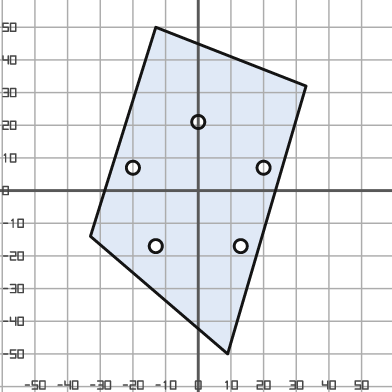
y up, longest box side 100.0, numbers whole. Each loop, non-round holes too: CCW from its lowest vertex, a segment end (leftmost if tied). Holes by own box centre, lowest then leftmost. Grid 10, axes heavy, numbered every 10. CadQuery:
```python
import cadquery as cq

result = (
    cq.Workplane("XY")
    .moveTo(9.0, -50.0)
    .lineTo(33.0, 32.0)
    .lineTo(-13.0, 50.0)
    .lineTo(-33.0, -14.0)
    .close()
    .moveTo(-13.0, -17.0)
    .circle(2.0)
    .moveTo(13.0, -17.0)
    .circle(2.0)
    .moveTo(-20.0, 7.0)
    .circle(2.0)
    .moveTo(20.0, 7.0)
    .circle(2.0)
    .moveTo(0.0, 21.0)
    .circle(2.0)
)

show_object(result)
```